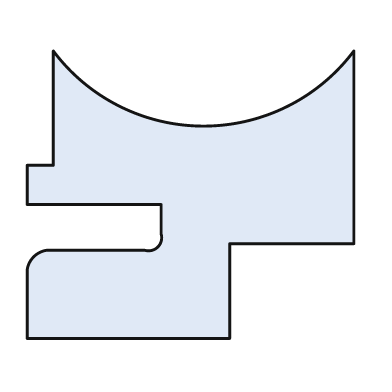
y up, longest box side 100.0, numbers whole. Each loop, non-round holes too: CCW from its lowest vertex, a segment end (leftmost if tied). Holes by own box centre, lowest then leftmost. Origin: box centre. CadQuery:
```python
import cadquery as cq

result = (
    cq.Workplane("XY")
    .moveTo(-50.0, -44.0)
    .lineTo(12.0, -44.0)
    .lineTo(12.0, -15.0)
    .lineTo(50.0, -15.0)
    .lineTo(50.0, 44.0)
    .threePointArc((4.0, 21.0), (-42.0, 44.0))
    .lineTo(-42.0, 9.0)
    .lineTo(-50.0, 9.0)
    .lineTo(-50.0, -3.0)
    .lineTo(-9.0, -3.0)
    .lineTo(-9.0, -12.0)
    .threePointArc((-10.0, -16.0), (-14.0, -17.0))
    .lineTo(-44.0, -17.0)
    .threePointArc((-48.0, -19.0), (-50.0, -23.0))
    .close()
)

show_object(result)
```